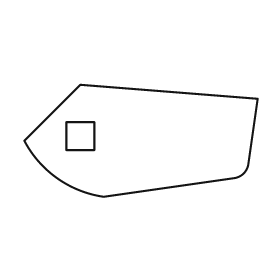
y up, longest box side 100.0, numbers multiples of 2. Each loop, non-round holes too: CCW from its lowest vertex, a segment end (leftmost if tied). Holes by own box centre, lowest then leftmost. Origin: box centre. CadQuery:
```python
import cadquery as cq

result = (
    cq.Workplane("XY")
    .moveTo(-16.0, -24.0)
    .lineTo(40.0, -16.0)
    .threePointArc((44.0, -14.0), (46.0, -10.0))
    .lineTo(50.0, 18.0)
    .lineTo(-26.0, 24.0)
    .lineTo(-50.0, 0.0)
    .threePointArc((-36.0, -16.0), (-16.0, -24.0))
    .close()
    .moveTo(-32.0, -4.0)
    .lineTo(-20.0, -4.0)
    .lineTo(-20.0, 8.0)
    .lineTo(-32.0, 8.0)
    .close()
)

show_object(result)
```